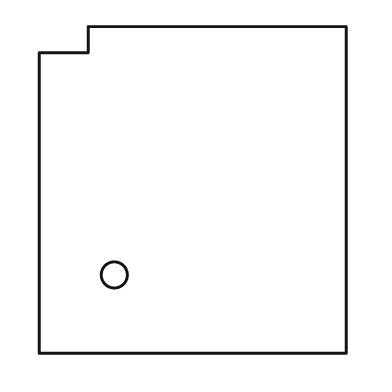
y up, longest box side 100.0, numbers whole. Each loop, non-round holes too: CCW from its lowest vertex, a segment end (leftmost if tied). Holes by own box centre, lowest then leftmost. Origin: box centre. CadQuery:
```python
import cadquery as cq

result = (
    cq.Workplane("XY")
    .moveTo(-47.0, -50.0)
    .lineTo(47.0, -50.0)
    .lineTo(47.0, 50.0)
    .lineTo(-32.0, 50.0)
    .lineTo(-32.0, 42.0)
    .lineTo(-47.0, 42.0)
    .close()
    .moveTo(-24.0, -26.0)
    .circle(4.0)
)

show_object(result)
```